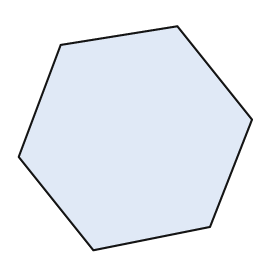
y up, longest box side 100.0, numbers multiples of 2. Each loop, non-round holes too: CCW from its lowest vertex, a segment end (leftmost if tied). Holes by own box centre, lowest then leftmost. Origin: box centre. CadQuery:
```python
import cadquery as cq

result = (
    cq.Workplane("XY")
    .moveTo(-18.0, -48.0)
    .lineTo(32.0, -38.0)
    .lineTo(50.0, 8.0)
    .lineTo(18.0, 48.0)
    .lineTo(-32.0, 40.0)
    .lineTo(-50.0, -8.0)
    .close()
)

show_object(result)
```